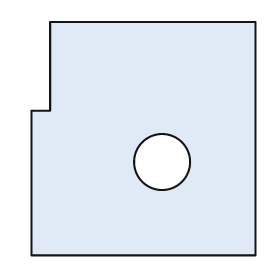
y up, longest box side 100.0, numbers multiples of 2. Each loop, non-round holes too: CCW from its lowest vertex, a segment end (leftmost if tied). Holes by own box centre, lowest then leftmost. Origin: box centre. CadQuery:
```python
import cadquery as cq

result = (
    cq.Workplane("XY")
    .moveTo(-48.0, -50.0)
    .lineTo(48.0, -50.0)
    .lineTo(48.0, 50.0)
    .lineTo(-40.0, 50.0)
    .lineTo(-40.0, 12.0)
    .lineTo(-48.0, 12.0)
    .close()
    .moveTo(8.0, -10.0)
    .circle(12.0)
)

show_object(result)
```